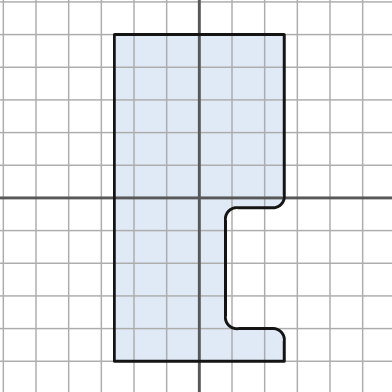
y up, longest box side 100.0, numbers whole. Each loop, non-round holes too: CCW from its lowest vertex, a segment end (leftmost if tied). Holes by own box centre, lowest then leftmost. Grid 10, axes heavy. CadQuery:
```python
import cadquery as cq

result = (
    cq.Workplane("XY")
    .moveTo(-26.0, -50.0)
    .lineTo(26.0, -50.0)
    .lineTo(26.0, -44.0)
    .threePointArc((25.0, -41.0), (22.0, -40.0))
    .lineTo(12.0, -40.0)
    .threePointArc((9.0, -39.0), (8.0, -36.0))
    .lineTo(8.0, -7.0)
    .threePointArc((9.0, -4.0), (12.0, -3.0))
    .lineTo(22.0, -3.0)
    .threePointArc((25.0, -2.0), (26.0, 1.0))
    .lineTo(26.0, 50.0)
    .lineTo(-26.0, 50.0)
    .close()
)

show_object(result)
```